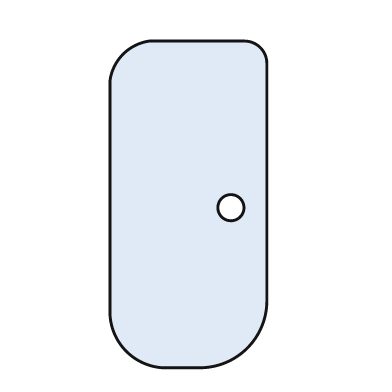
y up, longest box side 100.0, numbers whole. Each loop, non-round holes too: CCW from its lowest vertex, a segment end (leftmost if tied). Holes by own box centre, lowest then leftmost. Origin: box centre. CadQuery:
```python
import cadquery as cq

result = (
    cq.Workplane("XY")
    .moveTo(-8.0, -50.0)
    .lineTo(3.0, -50.0)
    .threePointArc((18.0, -44.0), (24.0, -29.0))
    .lineTo(24.0, 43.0)
    .threePointArc((22.0, 48.0), (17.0, 50.0))
    .lineTo(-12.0, 50.0)
    .threePointArc((-20.0, 46.0), (-24.0, 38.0))
    .lineTo(-24.0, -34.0)
    .threePointArc((-19.0, -45.0), (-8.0, -50.0))
    .close()
    .moveTo(13.0, -1.0)
    .circle(4.0)
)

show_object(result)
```